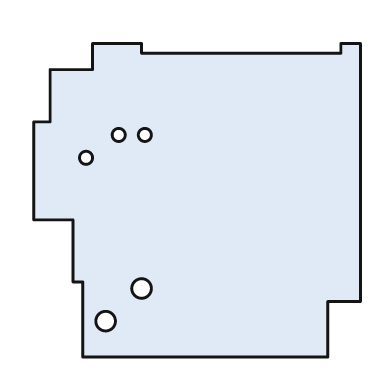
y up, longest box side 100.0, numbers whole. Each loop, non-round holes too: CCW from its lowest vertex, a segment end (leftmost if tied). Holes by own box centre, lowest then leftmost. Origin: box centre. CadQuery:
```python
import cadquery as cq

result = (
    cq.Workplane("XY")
    .moveTo(-35.0, -48.0)
    .lineTo(40.0, -48.0)
    .lineTo(40.0, -31.0)
    .lineTo(50.0, -31.0)
    .lineTo(50.0, 48.0)
    .lineTo(44.0, 48.0)
    .lineTo(44.0, 45.0)
    .lineTo(-17.0, 45.0)
    .lineTo(-17.0, 48.0)
    .lineTo(-32.0, 48.0)
    .lineTo(-32.0, 40.0)
    .lineTo(-45.0, 40.0)
    .lineTo(-45.0, 24.0)
    .lineTo(-50.0, 24.0)
    .lineTo(-50.0, -6.0)
    .lineTo(-38.0, -6.0)
    .lineTo(-38.0, -25.0)
    .lineTo(-35.0, -25.0)
    .close()
    .moveTo(-28.0, -37.0)
    .circle(3.0)
    .moveTo(-17.0, -27.0)
    .circle(3.0)
    .moveTo(-34.0, 13.0)
    .circle(2.0)
    .moveTo(-24.0, 20.0)
    .circle(2.0)
    .moveTo(-16.0, 20.0)
    .circle(2.0)
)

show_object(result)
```